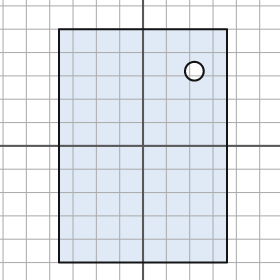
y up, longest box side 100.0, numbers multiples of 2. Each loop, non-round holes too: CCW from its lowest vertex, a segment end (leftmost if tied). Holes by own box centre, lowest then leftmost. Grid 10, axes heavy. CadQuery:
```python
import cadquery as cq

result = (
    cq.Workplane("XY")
    .moveTo(-36.0, -50.0)
    .lineTo(36.0, -50.0)
    .lineTo(36.0, 50.0)
    .lineTo(-36.0, 50.0)
    .close()
    .moveTo(22.0, 32.0)
    .circle(4.0)
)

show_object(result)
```